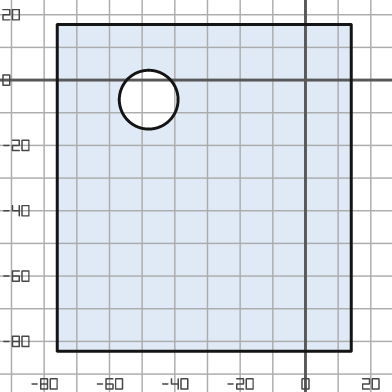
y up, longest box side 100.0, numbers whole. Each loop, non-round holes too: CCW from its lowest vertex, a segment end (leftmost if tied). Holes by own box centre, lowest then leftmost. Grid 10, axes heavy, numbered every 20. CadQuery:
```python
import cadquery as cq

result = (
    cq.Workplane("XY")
    .moveTo(-76.0, -83.0)
    .lineTo(14.0, -83.0)
    .lineTo(14.0, 17.0)
    .lineTo(-76.0, 17.0)
    .close()
    .moveTo(-48.0, -6.0)
    .circle(9.0)
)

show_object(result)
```